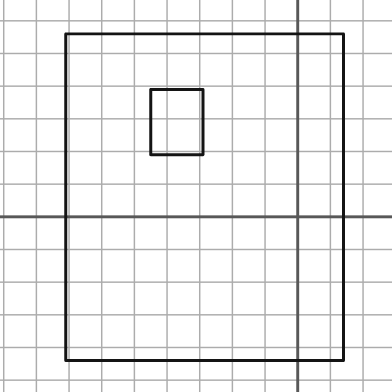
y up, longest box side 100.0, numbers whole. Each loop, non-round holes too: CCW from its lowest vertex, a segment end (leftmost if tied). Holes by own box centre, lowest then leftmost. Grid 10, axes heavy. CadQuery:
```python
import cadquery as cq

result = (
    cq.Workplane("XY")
    .moveTo(-71.0, -44.0)
    .lineTo(14.0, -44.0)
    .lineTo(14.0, 56.0)
    .lineTo(-71.0, 56.0)
    .close()
    .moveTo(-45.0, 19.0)
    .lineTo(-29.0, 19.0)
    .lineTo(-29.0, 39.0)
    .lineTo(-45.0, 39.0)
    .close()
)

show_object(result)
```